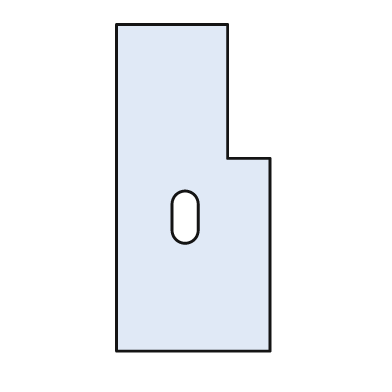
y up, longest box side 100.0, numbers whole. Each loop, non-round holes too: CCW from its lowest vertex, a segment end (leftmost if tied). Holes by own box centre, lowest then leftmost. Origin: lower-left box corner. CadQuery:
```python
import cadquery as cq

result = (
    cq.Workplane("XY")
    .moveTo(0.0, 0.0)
    .lineTo(47.0, 0.0)
    .lineTo(47.0, 59.0)
    .lineTo(34.0, 59.0)
    .lineTo(34.0, 100.0)
    .lineTo(0.0, 100.0)
    .close()
    .moveTo(17.0, 37.0)
    .threePointArc((21.0, 33.0), (25.0, 37.0))
    .lineTo(25.0, 45.0)
    .threePointArc((21.0, 49.0), (17.0, 45.0))
    .close()
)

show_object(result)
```